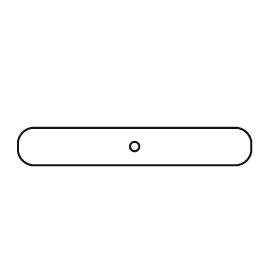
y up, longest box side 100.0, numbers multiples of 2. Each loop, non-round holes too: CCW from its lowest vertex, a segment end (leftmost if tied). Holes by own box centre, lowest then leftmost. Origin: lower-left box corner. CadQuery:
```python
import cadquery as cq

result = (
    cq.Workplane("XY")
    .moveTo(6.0, 0.0)
    .lineTo(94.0, 0.0)
    .threePointArc((98.0, 2.0), (100.0, 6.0))
    .lineTo(100.0, 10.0)
    .threePointArc((98.0, 14.0), (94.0, 16.0))
    .lineTo(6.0, 16.0)
    .threePointArc((2.0, 14.0), (0.0, 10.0))
    .lineTo(0.0, 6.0)
    .threePointArc((2.0, 2.0), (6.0, 0.0))
    .close()
    .moveTo(50.0, 8.0)
    .circle(2.0)
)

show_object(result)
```